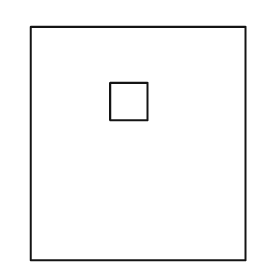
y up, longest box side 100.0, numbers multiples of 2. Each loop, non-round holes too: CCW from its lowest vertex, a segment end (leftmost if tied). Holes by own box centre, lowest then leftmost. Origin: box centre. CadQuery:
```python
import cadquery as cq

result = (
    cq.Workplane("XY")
    .moveTo(-46.0, -50.0)
    .lineTo(46.0, -50.0)
    .lineTo(46.0, 50.0)
    .lineTo(-46.0, 50.0)
    .close()
    .moveTo(-12.0, 10.0)
    .lineTo(4.0, 10.0)
    .lineTo(4.0, 26.0)
    .lineTo(-12.0, 26.0)
    .close()
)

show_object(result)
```